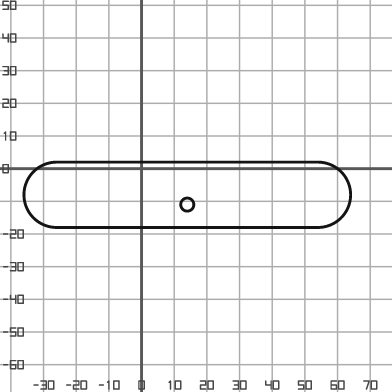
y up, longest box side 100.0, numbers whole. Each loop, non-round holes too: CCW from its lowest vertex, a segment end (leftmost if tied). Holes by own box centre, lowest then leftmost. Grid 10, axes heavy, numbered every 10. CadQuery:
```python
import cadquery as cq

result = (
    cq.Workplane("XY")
    .moveTo(-26.0, -18.0)
    .lineTo(54.0, -18.0)
    .threePointArc((64.0, -8.0), (54.0, 2.0))
    .lineTo(-26.0, 2.0)
    .threePointArc((-36.0, -8.0), (-26.0, -18.0))
    .close()
    .moveTo(14.0, -11.0)
    .circle(2.0)
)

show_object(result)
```